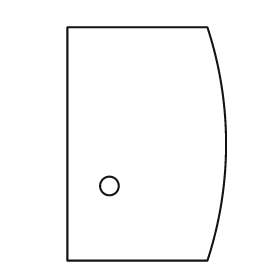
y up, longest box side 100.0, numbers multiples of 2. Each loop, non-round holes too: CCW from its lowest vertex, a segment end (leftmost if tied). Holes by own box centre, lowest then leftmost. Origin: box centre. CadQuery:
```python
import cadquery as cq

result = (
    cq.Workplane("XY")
    .moveTo(-34.0, -50.0)
    .lineTo(26.0, -50.0)
    .threePointArc((34.0, 0.0), (26.0, 50.0))
    .lineTo(-34.0, 50.0)
    .close()
    .moveTo(-16.0, -18.0)
    .circle(4.0)
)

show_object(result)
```